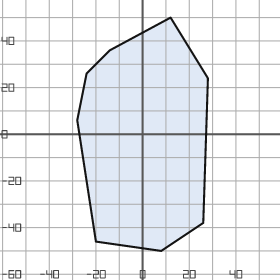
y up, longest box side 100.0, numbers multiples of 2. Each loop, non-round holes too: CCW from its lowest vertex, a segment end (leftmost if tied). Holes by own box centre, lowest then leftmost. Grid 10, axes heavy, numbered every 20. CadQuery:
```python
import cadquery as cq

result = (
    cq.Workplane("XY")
    .moveTo(8.0, -50.0)
    .lineTo(26.0, -38.0)
    .lineTo(28.0, 24.0)
    .lineTo(12.0, 50.0)
    .lineTo(-14.0, 36.0)
    .lineTo(-24.0, 26.0)
    .lineTo(-28.0, 6.0)
    .lineTo(-20.0, -46.0)
    .close()
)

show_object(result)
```